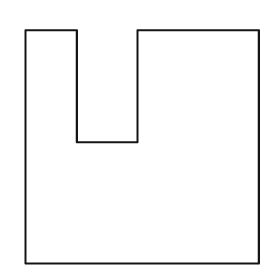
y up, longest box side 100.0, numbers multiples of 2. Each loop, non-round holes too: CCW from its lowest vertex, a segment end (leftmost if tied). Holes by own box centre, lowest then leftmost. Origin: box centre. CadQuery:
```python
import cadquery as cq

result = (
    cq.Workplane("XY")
    .moveTo(-50.0, -50.0)
    .lineTo(50.0, -50.0)
    .lineTo(50.0, 50.0)
    .lineTo(-2.0, 50.0)
    .lineTo(-2.0, 2.0)
    .lineTo(-28.0, 2.0)
    .lineTo(-28.0, 50.0)
    .lineTo(-50.0, 50.0)
    .close()
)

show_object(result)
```